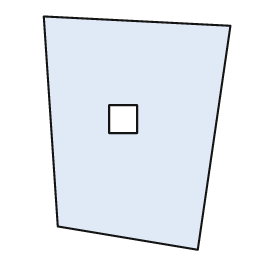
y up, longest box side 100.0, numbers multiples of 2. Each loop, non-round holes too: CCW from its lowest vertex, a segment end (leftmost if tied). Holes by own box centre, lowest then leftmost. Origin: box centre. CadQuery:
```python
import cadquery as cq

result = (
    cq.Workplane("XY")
    .moveTo(26.0, -50.0)
    .lineTo(40.0, 46.0)
    .lineTo(-40.0, 50.0)
    .lineTo(-34.0, -40.0)
    .close()
    .moveTo(-12.0, 0.0)
    .lineTo(0.0, 0.0)
    .lineTo(0.0, 12.0)
    .lineTo(-12.0, 12.0)
    .close()
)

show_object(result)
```